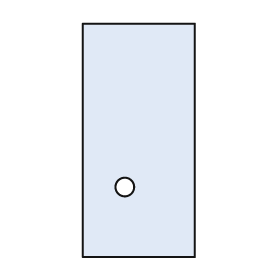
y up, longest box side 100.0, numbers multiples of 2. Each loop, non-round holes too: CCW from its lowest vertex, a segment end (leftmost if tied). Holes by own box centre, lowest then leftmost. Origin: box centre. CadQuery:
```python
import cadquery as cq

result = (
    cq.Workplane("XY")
    .moveTo(-24.0, -50.0)
    .lineTo(24.0, -50.0)
    .lineTo(24.0, 50.0)
    .lineTo(-24.0, 50.0)
    .close()
    .moveTo(-6.0, -20.0)
    .circle(4.0)
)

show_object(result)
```